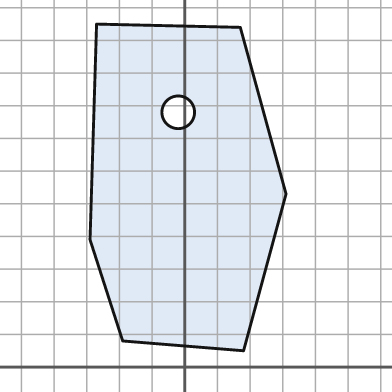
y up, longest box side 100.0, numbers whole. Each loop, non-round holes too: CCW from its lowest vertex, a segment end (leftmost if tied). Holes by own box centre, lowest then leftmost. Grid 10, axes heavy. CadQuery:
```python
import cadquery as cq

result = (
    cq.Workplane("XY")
    .moveTo(18.0, 5.0)
    .lineTo(31.0, 53.0)
    .lineTo(17.0, 104.0)
    .lineTo(-27.0, 105.0)
    .lineTo(-29.0, 39.0)
    .lineTo(-19.0, 8.0)
    .close()
    .moveTo(-2.0, 78.0)
    .circle(5.0)
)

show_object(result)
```